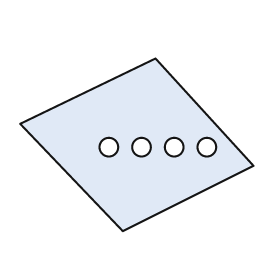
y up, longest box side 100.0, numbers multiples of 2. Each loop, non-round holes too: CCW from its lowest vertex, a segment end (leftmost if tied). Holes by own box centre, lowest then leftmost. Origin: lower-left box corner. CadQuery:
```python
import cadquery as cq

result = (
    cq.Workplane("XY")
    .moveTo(44.0, 0.0)
    .lineTo(100.0, 28.0)
    .lineTo(58.0, 74.0)
    .lineTo(0.0, 46.0)
    .close()
    .moveTo(38.0, 36.0)
    .circle(4.0)
    .moveTo(52.0, 36.0)
    .circle(4.0)
    .moveTo(66.0, 36.0)
    .circle(4.0)
    .moveTo(80.0, 36.0)
    .circle(4.0)
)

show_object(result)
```